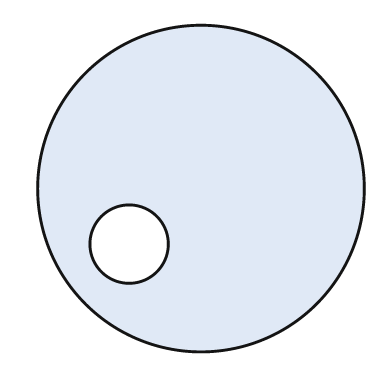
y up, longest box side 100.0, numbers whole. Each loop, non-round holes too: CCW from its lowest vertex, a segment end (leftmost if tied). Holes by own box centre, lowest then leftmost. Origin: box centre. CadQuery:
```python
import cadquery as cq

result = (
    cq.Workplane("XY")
    .moveTo(0.0, 0.0)
    .circle(50.0)
    .moveTo(-22.0, -17.0)
    .circle(12.0)
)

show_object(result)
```